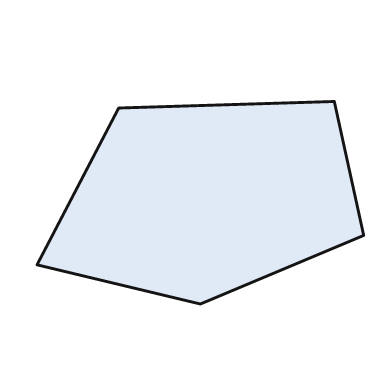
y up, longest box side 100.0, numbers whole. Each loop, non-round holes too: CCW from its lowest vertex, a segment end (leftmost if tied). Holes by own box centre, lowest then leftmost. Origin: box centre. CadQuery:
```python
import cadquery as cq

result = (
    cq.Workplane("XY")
    .moveTo(0.0, -31.0)
    .lineTo(50.0, -10.0)
    .lineTo(41.0, 31.0)
    .lineTo(-25.0, 29.0)
    .lineTo(-50.0, -19.0)
    .close()
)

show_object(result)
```